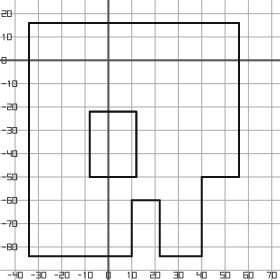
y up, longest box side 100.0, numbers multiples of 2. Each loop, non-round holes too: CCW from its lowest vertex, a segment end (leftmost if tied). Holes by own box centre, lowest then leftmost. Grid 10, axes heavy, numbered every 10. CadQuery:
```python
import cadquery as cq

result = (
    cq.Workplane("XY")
    .moveTo(-34.0, -84.0)
    .lineTo(10.0, -84.0)
    .lineTo(10.0, -60.0)
    .lineTo(22.0, -60.0)
    .lineTo(22.0, -84.0)
    .lineTo(40.0, -84.0)
    .lineTo(40.0, -50.0)
    .lineTo(56.0, -50.0)
    .lineTo(56.0, 16.0)
    .lineTo(-34.0, 16.0)
    .close()
    .moveTo(-8.0, -50.0)
    .lineTo(12.0, -50.0)
    .lineTo(12.0, -22.0)
    .lineTo(-8.0, -22.0)
    .close()
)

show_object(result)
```